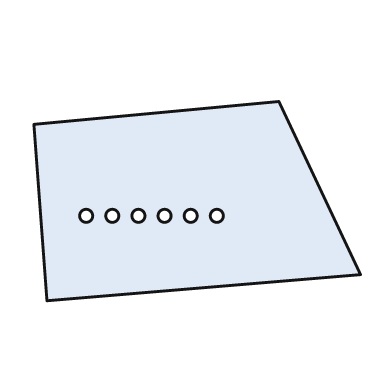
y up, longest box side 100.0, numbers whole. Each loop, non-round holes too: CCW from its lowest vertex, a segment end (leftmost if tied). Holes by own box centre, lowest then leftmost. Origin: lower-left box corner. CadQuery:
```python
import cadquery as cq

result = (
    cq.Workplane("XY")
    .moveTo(4.0, 0.0)
    .lineTo(100.0, 8.0)
    .lineTo(75.0, 61.0)
    .lineTo(0.0, 54.0)
    .close()
    .moveTo(16.0, 26.0)
    .circle(2.0)
    .moveTo(24.0, 26.0)
    .circle(2.0)
    .moveTo(32.0, 26.0)
    .circle(2.0)
    .moveTo(40.0, 26.0)
    .circle(2.0)
    .moveTo(48.0, 26.0)
    .circle(2.0)
    .moveTo(56.0, 26.0)
    .circle(2.0)
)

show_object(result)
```